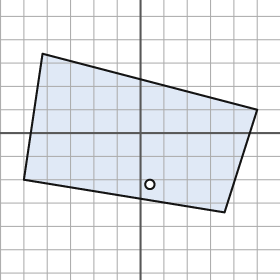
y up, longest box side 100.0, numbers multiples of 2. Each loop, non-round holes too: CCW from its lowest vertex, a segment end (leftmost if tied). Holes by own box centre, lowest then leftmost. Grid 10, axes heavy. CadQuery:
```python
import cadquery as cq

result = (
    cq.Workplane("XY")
    .moveTo(36.0, -34.0)
    .lineTo(50.0, 10.0)
    .lineTo(-42.0, 34.0)
    .lineTo(-50.0, -20.0)
    .close()
    .moveTo(4.0, -22.0)
    .circle(2.0)
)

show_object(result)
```